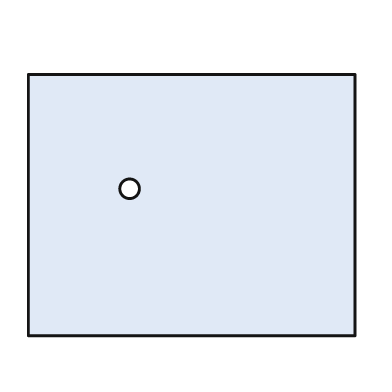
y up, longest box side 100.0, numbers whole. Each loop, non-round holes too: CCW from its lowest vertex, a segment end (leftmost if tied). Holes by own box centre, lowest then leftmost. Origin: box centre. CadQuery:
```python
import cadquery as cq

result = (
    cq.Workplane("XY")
    .moveTo(-50.0, -40.0)
    .lineTo(50.0, -40.0)
    .lineTo(50.0, 40.0)
    .lineTo(-50.0, 40.0)
    .close()
    .moveTo(-19.0, 5.0)
    .circle(3.0)
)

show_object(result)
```